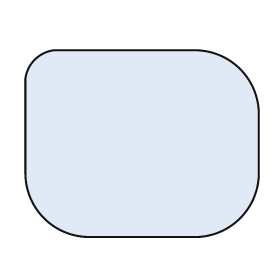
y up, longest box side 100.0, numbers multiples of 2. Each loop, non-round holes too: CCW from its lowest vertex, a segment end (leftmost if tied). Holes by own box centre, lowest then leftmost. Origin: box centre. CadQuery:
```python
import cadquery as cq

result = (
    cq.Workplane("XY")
    .moveTo(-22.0, -40.0)
    .lineTo(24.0, -40.0)
    .threePointArc((42.0, -32.0), (50.0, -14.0))
    .lineTo(50.0, 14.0)
    .threePointArc((42.0, 32.0), (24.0, 40.0))
    .lineTo(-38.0, 40.0)
    .threePointArc((-46.0, 36.0), (-50.0, 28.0))
    .lineTo(-50.0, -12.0)
    .threePointArc((-42.0, -32.0), (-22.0, -40.0))
    .close()
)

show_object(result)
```